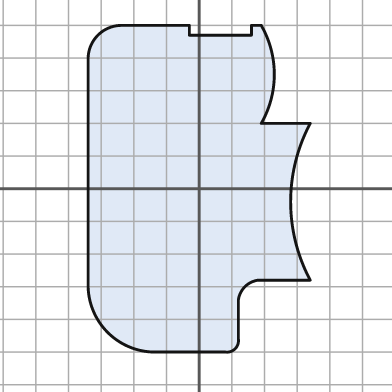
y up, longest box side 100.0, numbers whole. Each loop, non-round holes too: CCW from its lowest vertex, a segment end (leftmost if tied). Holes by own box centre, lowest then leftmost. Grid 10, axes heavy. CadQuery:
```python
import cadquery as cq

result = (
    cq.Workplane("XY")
    .moveTo(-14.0, -50.0)
    .lineTo(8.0, -50.0)
    .threePointArc((11.0, -49.0), (12.0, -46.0))
    .lineTo(12.0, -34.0)
    .threePointArc((14.0, -30.0), (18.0, -28.0))
    .lineTo(34.0, -28.0)
    .threePointArc((28.0, -4.0), (34.0, 20.0))
    .lineTo(19.0, 20.0)
    .threePointArc((23.0, 35.0), (19.0, 50.0))
    .lineTo(16.0, 50.0)
    .lineTo(16.0, 47.0)
    .lineTo(-3.0, 47.0)
    .lineTo(-3.0, 50.0)
    .lineTo(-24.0, 50.0)
    .threePointArc((-31.0, 47.0), (-34.0, 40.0))
    .lineTo(-34.0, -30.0)
    .threePointArc((-28.0, -44.0), (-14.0, -50.0))
    .close()
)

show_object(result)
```